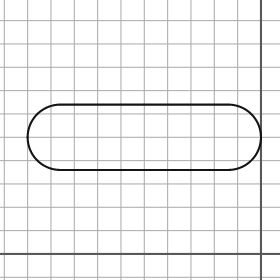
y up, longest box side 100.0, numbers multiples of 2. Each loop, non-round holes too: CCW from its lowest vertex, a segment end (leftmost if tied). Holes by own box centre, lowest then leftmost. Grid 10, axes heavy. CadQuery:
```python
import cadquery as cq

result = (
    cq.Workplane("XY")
    .moveTo(-86.0, 36.0)
    .lineTo(-14.0, 36.0)
    .threePointArc((0.0, 50.0), (-14.0, 64.0))
    .lineTo(-86.0, 64.0)
    .threePointArc((-100.0, 50.0), (-86.0, 36.0))
    .close()
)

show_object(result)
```